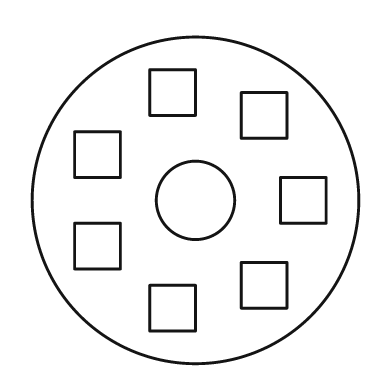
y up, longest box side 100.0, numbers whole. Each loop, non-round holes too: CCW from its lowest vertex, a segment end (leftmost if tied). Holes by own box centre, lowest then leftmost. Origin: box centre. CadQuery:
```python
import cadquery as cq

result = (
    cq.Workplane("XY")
    .moveTo(0.0, 0.0)
    .circle(50.0)
    .moveTo(-14.0, -40.0)
    .lineTo(0.0, -40.0)
    .lineTo(0.0, -26.0)
    .lineTo(-14.0, -26.0)
    .close()
    .moveTo(14.0, -33.0)
    .lineTo(28.0, -33.0)
    .lineTo(28.0, -19.0)
    .lineTo(14.0, -19.0)
    .close()
    .moveTo(-37.0, -21.0)
    .lineTo(-23.0, -21.0)
    .lineTo(-23.0, -7.0)
    .lineTo(-37.0, -7.0)
    .close()
    .moveTo(0.0, 0.0)
    .circle(12.0)
    .moveTo(26.0, -7.0)
    .lineTo(40.0, -7.0)
    .lineTo(40.0, 7.0)
    .lineTo(26.0, 7.0)
    .close()
    .moveTo(-37.0, 7.0)
    .lineTo(-23.0, 7.0)
    .lineTo(-23.0, 21.0)
    .lineTo(-37.0, 21.0)
    .close()
    .moveTo(14.0, 19.0)
    .lineTo(28.0, 19.0)
    .lineTo(28.0, 33.0)
    .lineTo(14.0, 33.0)
    .close()
    .moveTo(-14.0, 26.0)
    .lineTo(0.0, 26.0)
    .lineTo(0.0, 40.0)
    .lineTo(-14.0, 40.0)
    .close()
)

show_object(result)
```